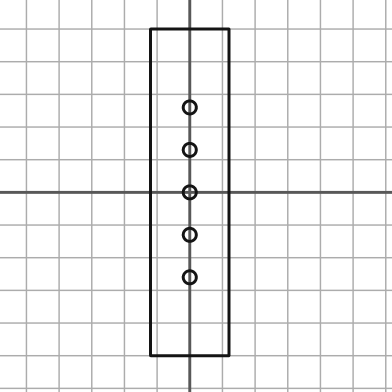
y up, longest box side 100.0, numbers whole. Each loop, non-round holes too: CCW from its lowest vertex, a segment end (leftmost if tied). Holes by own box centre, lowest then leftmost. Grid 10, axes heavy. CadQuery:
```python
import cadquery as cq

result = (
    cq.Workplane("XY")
    .moveTo(-12.0, -50.0)
    .lineTo(12.0, -50.0)
    .lineTo(12.0, 50.0)
    .lineTo(-12.0, 50.0)
    .close()
    .moveTo(0.0, -26.0)
    .circle(2.0)
    .moveTo(0.0, -13.0)
    .circle(2.0)
    .moveTo(0.0, 0.0)
    .circle(2.0)
    .moveTo(0.0, 13.0)
    .circle(2.0)
    .moveTo(0.0, 26.0)
    .circle(2.0)
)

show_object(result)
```